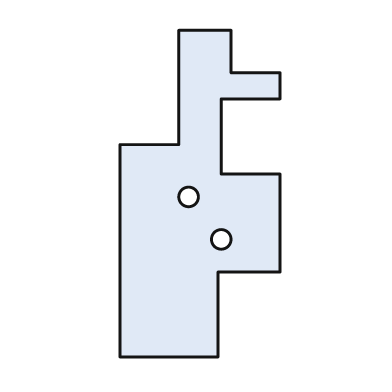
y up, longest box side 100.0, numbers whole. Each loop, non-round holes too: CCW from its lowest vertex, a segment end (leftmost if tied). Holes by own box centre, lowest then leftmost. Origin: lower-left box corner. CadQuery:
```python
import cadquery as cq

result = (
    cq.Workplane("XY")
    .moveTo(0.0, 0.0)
    .lineTo(30.0, 0.0)
    .lineTo(30.0, 26.0)
    .lineTo(49.0, 26.0)
    .lineTo(49.0, 56.0)
    .lineTo(31.0, 56.0)
    .lineTo(31.0, 79.0)
    .lineTo(49.0, 79.0)
    .lineTo(49.0, 87.0)
    .lineTo(34.0, 87.0)
    .lineTo(34.0, 100.0)
    .lineTo(18.0, 100.0)
    .lineTo(18.0, 65.0)
    .lineTo(0.0, 65.0)
    .close()
    .moveTo(31.0, 36.0)
    .circle(3.0)
    .moveTo(21.0, 49.0)
    .circle(3.0)
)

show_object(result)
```